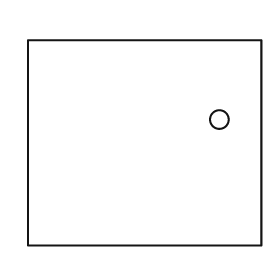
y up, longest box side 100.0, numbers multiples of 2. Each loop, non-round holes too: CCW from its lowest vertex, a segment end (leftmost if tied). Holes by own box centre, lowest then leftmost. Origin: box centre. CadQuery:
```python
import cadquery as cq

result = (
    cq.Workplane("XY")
    .moveTo(-50.0, -44.0)
    .lineTo(50.0, -44.0)
    .lineTo(50.0, 44.0)
    .lineTo(-50.0, 44.0)
    .close()
    .moveTo(32.0, 10.0)
    .circle(4.0)
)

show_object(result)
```